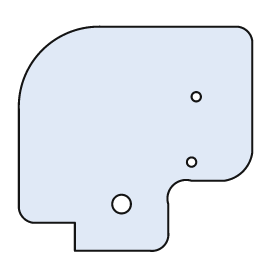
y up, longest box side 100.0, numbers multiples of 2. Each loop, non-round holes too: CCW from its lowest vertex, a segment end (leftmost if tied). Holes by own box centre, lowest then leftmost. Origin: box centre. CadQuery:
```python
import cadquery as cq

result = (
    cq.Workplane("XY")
    .moveTo(-26.0, -48.0)
    .lineTo(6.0, -48.0)
    .threePointArc((12.0, -46.0), (14.0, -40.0))
    .lineTo(14.0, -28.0)
    .threePointArc((16.0, -20.0), (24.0, -18.0))
    .lineTo(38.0, -18.0)
    .threePointArc((46.0, -14.0), (50.0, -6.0))
    .lineTo(50.0, 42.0)
    .threePointArc((48.0, 46.0), (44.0, 48.0))
    .lineTo(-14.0, 48.0)
    .threePointArc((-40.0, 38.0), (-50.0, 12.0))
    .lineTo(-50.0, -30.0)
    .threePointArc((-48.0, -34.0), (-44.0, -36.0))
    .lineTo(-26.0, -36.0)
    .close()
    .moveTo(-6.0, -28.0)
    .circle(4.0)
    .moveTo(24.0, -10.0)
    .circle(2.0)
    .moveTo(26.0, 18.0)
    .circle(2.0)
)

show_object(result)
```